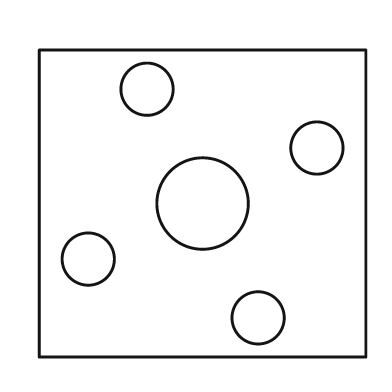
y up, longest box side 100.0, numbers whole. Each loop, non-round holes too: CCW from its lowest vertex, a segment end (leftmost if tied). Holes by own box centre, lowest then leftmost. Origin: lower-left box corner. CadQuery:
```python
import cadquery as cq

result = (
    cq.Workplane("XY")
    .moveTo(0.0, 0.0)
    .lineTo(100.0, 0.0)
    .lineTo(100.0, 94.0)
    .lineTo(0.0, 94.0)
    .close()
    .moveTo(67.0, 12.0)
    .circle(8.0)
    .moveTo(15.0, 30.0)
    .circle(8.0)
    .moveTo(50.0, 47.0)
    .circle(14.0)
    .moveTo(85.0, 64.0)
    .circle(8.0)
    .moveTo(33.0, 82.0)
    .circle(8.0)
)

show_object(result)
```